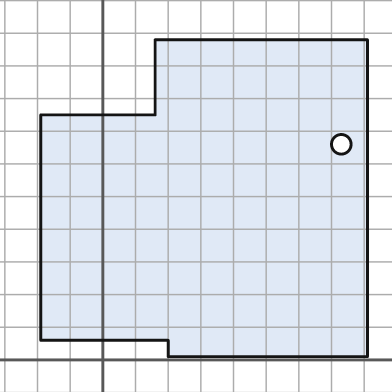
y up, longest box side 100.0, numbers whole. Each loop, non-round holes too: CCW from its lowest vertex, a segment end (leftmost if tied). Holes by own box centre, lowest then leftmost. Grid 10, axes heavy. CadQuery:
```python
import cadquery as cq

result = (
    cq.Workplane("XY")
    .moveTo(20.0, 1.0)
    .lineTo(81.0, 1.0)
    .lineTo(81.0, 98.0)
    .lineTo(16.0, 98.0)
    .lineTo(16.0, 75.0)
    .lineTo(-19.0, 75.0)
    .lineTo(-19.0, 6.0)
    .lineTo(20.0, 6.0)
    .close()
    .moveTo(73.0, 66.0)
    .circle(3.0)
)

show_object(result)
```